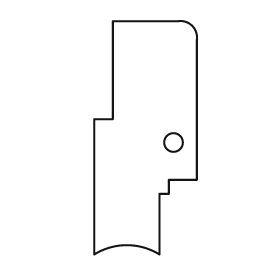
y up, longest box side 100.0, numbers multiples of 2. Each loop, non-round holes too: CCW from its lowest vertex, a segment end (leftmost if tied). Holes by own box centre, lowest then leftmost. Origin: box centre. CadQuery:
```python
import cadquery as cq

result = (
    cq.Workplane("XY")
    .moveTo(-22.0, -50.0)
    .threePointArc((-8.0, -46.0), (6.0, -50.0))
    .lineTo(6.0, -24.0)
    .lineTo(10.0, -24.0)
    .lineTo(10.0, -18.0)
    .lineTo(22.0, -18.0)
    .lineTo(22.0, 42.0)
    .threePointArc((20.0, 48.0), (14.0, 50.0))
    .lineTo(-14.0, 50.0)
    .lineTo(-14.0, 8.0)
    .lineTo(-22.0, 8.0)
    .close()
    .moveTo(12.0, -2.0)
    .circle(4.0)
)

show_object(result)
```